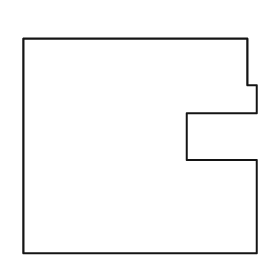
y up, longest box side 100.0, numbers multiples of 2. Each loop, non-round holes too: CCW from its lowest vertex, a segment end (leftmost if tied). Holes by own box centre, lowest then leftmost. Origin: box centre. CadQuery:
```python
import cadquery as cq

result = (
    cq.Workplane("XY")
    .moveTo(-50.0, -46.0)
    .lineTo(50.0, -46.0)
    .lineTo(50.0, -6.0)
    .lineTo(20.0, -6.0)
    .lineTo(20.0, 14.0)
    .lineTo(50.0, 14.0)
    .lineTo(50.0, 26.0)
    .lineTo(46.0, 26.0)
    .lineTo(46.0, 46.0)
    .lineTo(-50.0, 46.0)
    .close()
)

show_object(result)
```